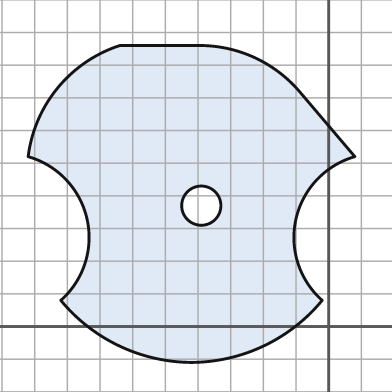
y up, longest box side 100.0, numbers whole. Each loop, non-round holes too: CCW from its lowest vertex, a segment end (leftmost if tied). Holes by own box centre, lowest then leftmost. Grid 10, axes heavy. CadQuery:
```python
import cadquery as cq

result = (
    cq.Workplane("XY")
    .moveTo(-42.0, -11.0)
    .threePointArc((-20.0, -6.0), (-2.0, 8.0))
    .threePointArc((-10.0, 33.0), (8.0, 52.0))
    .lineTo(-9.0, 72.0)
    .threePointArc((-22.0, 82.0), (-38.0, 86.0))
    .lineTo(-64.0, 86.0)
    .threePointArc((-83.0, 73.0), (-92.0, 52.0))
    .threePointArc((-74.0, 33.0), (-82.0, 8.0))
    .threePointArc((-64.0, -6.0), (-42.0, -11.0))
    .close()
    .moveTo(-39.0, 37.0)
    .circle(6.0)
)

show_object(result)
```